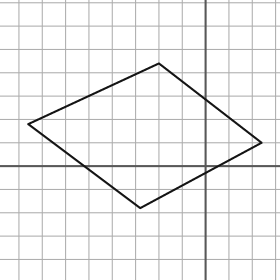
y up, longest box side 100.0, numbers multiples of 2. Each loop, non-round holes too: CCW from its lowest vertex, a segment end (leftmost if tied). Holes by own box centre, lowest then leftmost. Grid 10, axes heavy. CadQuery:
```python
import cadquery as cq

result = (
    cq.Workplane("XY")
    .moveTo(-28.0, -18.0)
    .lineTo(24.0, 10.0)
    .lineTo(-20.0, 44.0)
    .lineTo(-76.0, 18.0)
    .close()
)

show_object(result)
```